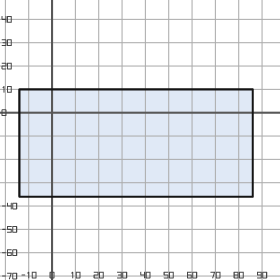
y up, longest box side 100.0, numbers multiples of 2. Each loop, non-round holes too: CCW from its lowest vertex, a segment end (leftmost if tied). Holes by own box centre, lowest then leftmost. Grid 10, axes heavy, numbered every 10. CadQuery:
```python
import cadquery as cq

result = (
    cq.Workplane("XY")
    .moveTo(-14.0, -36.0)
    .lineTo(86.0, -36.0)
    .lineTo(86.0, 10.0)
    .lineTo(-14.0, 10.0)
    .close()
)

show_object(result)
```